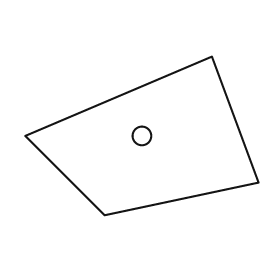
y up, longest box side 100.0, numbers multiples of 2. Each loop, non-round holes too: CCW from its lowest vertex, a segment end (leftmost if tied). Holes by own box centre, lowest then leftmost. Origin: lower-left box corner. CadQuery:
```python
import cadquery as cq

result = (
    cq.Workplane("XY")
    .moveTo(34.0, 0.0)
    .lineTo(100.0, 14.0)
    .lineTo(80.0, 68.0)
    .lineTo(0.0, 34.0)
    .close()
    .moveTo(50.0, 34.0)
    .circle(4.0)
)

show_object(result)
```